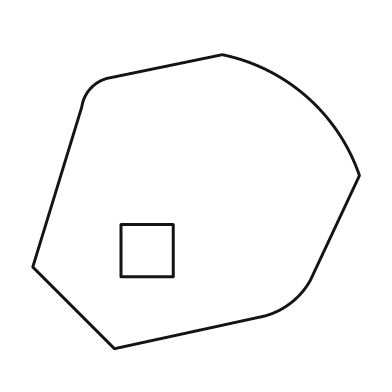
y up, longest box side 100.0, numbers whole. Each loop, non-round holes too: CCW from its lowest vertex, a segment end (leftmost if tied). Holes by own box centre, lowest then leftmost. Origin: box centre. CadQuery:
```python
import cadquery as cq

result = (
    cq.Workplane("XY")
    .moveTo(-25.0, -45.0)
    .lineTo(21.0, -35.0)
    .threePointArc((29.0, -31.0), (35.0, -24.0))
    .lineTo(50.0, 8.0)
    .threePointArc((34.0, 32.0), (8.0, 45.0))
    .lineTo(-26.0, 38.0)
    .threePointArc((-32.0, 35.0), (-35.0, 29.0))
    .lineTo(-50.0, -20.0)
    .close()
    .moveTo(-23.0, -23.0)
    .lineTo(-7.0, -23.0)
    .lineTo(-7.0, -7.0)
    .lineTo(-23.0, -7.0)
    .close()
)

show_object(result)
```